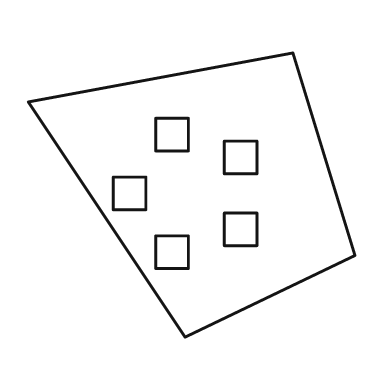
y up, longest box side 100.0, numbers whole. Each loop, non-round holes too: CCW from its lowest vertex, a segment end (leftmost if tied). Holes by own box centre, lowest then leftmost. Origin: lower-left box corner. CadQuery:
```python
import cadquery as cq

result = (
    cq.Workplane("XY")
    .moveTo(48.0, 0.0)
    .lineTo(100.0, 25.0)
    .lineTo(81.0, 87.0)
    .lineTo(0.0, 72.0)
    .close()
    .moveTo(39.0, 21.0)
    .lineTo(49.0, 21.0)
    .lineTo(49.0, 31.0)
    .lineTo(39.0, 31.0)
    .close()
    .moveTo(60.0, 28.0)
    .lineTo(70.0, 28.0)
    .lineTo(70.0, 38.0)
    .lineTo(60.0, 38.0)
    .close()
    .moveTo(26.0, 39.0)
    .lineTo(36.0, 39.0)
    .lineTo(36.0, 49.0)
    .lineTo(26.0, 49.0)
    .close()
    .moveTo(60.0, 50.0)
    .lineTo(70.0, 50.0)
    .lineTo(70.0, 60.0)
    .lineTo(60.0, 60.0)
    .close()
    .moveTo(39.0, 57.0)
    .lineTo(49.0, 57.0)
    .lineTo(49.0, 67.0)
    .lineTo(39.0, 67.0)
    .close()
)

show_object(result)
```